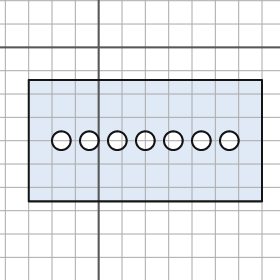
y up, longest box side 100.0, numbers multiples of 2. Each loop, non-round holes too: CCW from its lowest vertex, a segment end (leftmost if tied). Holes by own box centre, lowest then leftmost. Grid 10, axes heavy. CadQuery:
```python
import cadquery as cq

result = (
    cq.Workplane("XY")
    .moveTo(-30.0, -66.0)
    .lineTo(70.0, -66.0)
    .lineTo(70.0, -14.0)
    .lineTo(-30.0, -14.0)
    .close()
    .moveTo(-16.0, -40.0)
    .circle(4.0)
    .moveTo(-4.0, -40.0)
    .circle(4.0)
    .moveTo(8.0, -40.0)
    .circle(4.0)
    .moveTo(20.0, -40.0)
    .circle(4.0)
    .moveTo(32.0, -40.0)
    .circle(4.0)
    .moveTo(44.0, -40.0)
    .circle(4.0)
    .moveTo(56.0, -40.0)
    .circle(4.0)
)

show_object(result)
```